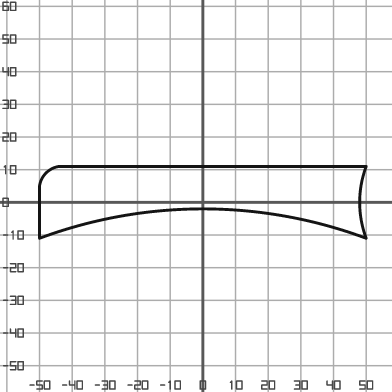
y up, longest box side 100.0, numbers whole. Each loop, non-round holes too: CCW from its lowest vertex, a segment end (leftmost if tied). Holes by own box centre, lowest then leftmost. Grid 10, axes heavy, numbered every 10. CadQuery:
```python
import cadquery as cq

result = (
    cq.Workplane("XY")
    .moveTo(-50.0, -11.0)
    .threePointArc((0.0, -2.0), (50.0, -11.0))
    .threePointArc((48.0, 0.0), (50.0, 11.0))
    .lineTo(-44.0, 11.0)
    .threePointArc((-48.0, 9.0), (-50.0, 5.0))
    .close()
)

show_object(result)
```